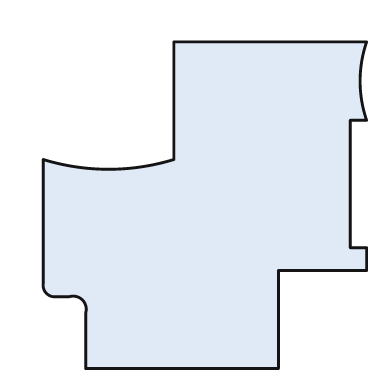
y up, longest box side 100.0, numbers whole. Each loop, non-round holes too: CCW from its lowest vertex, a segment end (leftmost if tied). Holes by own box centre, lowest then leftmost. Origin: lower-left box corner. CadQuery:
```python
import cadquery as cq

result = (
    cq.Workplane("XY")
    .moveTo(13.0, 0.0)
    .lineTo(72.0, 0.0)
    .lineTo(72.0, 30.0)
    .lineTo(99.0, 30.0)
    .lineTo(99.0, 37.0)
    .lineTo(94.0, 37.0)
    .lineTo(94.0, 76.0)
    .lineTo(99.0, 76.0)
    .threePointArc((97.0, 88.0), (99.0, 100.0))
    .lineTo(40.0, 100.0)
    .lineTo(40.0, 64.0)
    .threePointArc((20.0, 61.0), (0.0, 64.0))
    .lineTo(0.0, 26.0)
    .threePointArc((1.0, 23.0), (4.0, 22.0))
    .lineTo(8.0, 22.0)
    .threePointArc((12.0, 21.0), (13.0, 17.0))
    .close()
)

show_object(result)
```